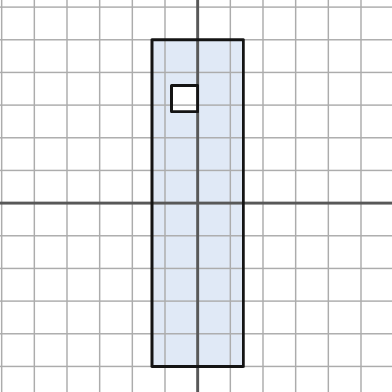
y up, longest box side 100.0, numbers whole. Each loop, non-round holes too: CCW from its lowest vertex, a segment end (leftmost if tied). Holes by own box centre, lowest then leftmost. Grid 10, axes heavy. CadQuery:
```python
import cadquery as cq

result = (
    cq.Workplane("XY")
    .moveTo(-14.0, -50.0)
    .lineTo(14.0, -50.0)
    .lineTo(14.0, 50.0)
    .lineTo(-14.0, 50.0)
    .close()
    .moveTo(-8.0, 28.0)
    .lineTo(0.0, 28.0)
    .lineTo(0.0, 36.0)
    .lineTo(-8.0, 36.0)
    .close()
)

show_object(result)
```